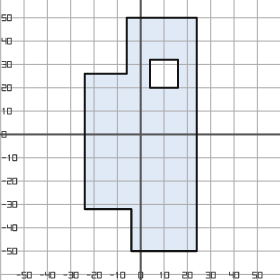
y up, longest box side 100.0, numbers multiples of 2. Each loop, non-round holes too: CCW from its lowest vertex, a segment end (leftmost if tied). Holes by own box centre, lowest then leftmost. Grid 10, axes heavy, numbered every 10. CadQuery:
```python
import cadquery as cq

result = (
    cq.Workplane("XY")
    .moveTo(-4.0, -50.0)
    .lineTo(24.0, -50.0)
    .lineTo(24.0, 50.0)
    .lineTo(-6.0, 50.0)
    .lineTo(-6.0, 26.0)
    .lineTo(-24.0, 26.0)
    .lineTo(-24.0, -32.0)
    .lineTo(-4.0, -32.0)
    .close()
    .moveTo(4.0, 20.0)
    .lineTo(16.0, 20.0)
    .lineTo(16.0, 32.0)
    .lineTo(4.0, 32.0)
    .close()
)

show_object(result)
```